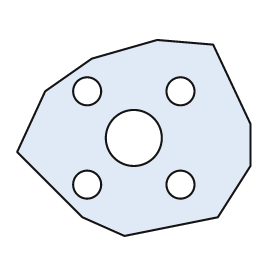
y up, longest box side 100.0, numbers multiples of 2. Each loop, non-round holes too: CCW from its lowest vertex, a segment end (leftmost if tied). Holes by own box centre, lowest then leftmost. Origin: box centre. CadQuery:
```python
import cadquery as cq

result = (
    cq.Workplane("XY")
    .moveTo(-4.0, -42.0)
    .lineTo(36.0, -34.0)
    .lineTo(50.0, -12.0)
    .lineTo(50.0, 6.0)
    .lineTo(34.0, 40.0)
    .lineTo(10.0, 42.0)
    .lineTo(-18.0, 34.0)
    .lineTo(-38.0, 20.0)
    .lineTo(-50.0, -6.0)
    .lineTo(-22.0, -34.0)
    .close()
    .moveTo(-20.0, -20.0)
    .circle(6.0)
    .moveTo(20.0, -20.0)
    .circle(6.0)
    .moveTo(0.0, 0.0)
    .circle(12.0)
    .moveTo(-20.0, 20.0)
    .circle(6.0)
    .moveTo(20.0, 20.0)
    .circle(6.0)
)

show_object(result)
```